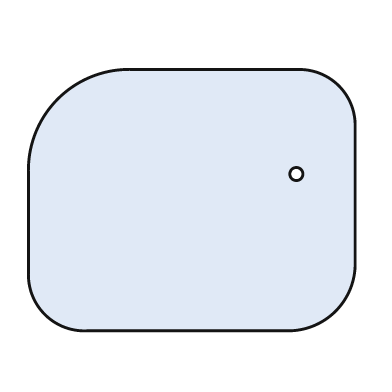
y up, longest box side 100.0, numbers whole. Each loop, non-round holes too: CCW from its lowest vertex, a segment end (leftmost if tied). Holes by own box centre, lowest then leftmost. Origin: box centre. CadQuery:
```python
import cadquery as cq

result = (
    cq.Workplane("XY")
    .moveTo(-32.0, -40.0)
    .lineTo(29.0, -40.0)
    .threePointArc((44.0, -34.0), (50.0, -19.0))
    .lineTo(50.0, 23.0)
    .threePointArc((45.0, 35.0), (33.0, 40.0))
    .lineTo(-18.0, 40.0)
    .threePointArc((-41.0, 31.0), (-50.0, 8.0))
    .lineTo(-50.0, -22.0)
    .threePointArc((-45.0, -35.0), (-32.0, -40.0))
    .close()
    .moveTo(32.0, 8.0)
    .circle(2.0)
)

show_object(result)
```